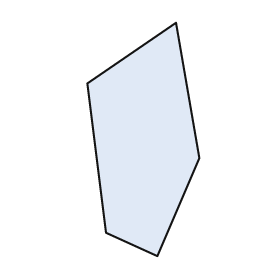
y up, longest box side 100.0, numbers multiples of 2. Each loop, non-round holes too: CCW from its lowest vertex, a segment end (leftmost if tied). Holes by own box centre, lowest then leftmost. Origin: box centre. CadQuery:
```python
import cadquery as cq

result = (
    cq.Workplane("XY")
    .moveTo(6.0, -50.0)
    .lineTo(24.0, -8.0)
    .lineTo(14.0, 50.0)
    .lineTo(-24.0, 24.0)
    .lineTo(-16.0, -40.0)
    .close()
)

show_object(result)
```